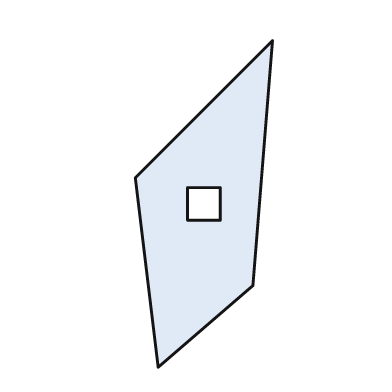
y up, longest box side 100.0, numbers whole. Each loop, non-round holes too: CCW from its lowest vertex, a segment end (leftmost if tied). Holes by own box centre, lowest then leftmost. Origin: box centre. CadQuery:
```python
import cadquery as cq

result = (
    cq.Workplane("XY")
    .moveTo(-14.0, -50.0)
    .lineTo(15.0, -25.0)
    .lineTo(21.0, 50.0)
    .lineTo(-21.0, 8.0)
    .close()
    .moveTo(-5.0, -5.0)
    .lineTo(5.0, -5.0)
    .lineTo(5.0, 5.0)
    .lineTo(-5.0, 5.0)
    .close()
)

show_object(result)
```